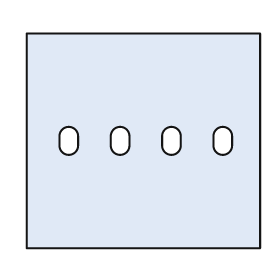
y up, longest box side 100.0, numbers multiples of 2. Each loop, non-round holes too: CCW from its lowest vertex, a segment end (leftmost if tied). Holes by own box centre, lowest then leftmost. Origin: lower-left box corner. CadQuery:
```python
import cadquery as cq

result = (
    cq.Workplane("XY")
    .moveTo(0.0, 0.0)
    .lineTo(100.0, 0.0)
    .lineTo(100.0, 92.0)
    .lineTo(0.0, 92.0)
    .close()
    .moveTo(14.0, 44.0)
    .threePointArc((18.0, 40.0), (22.0, 44.0))
    .lineTo(22.0, 48.0)
    .threePointArc((18.0, 52.0), (14.0, 48.0))
    .close()
    .moveTo(36.0, 44.0)
    .threePointArc((40.0, 40.0), (44.0, 44.0))
    .lineTo(44.0, 48.0)
    .threePointArc((40.0, 52.0), (36.0, 48.0))
    .close()
    .moveTo(58.0, 44.0)
    .threePointArc((62.0, 40.0), (66.0, 44.0))
    .lineTo(66.0, 48.0)
    .threePointArc((62.0, 52.0), (58.0, 48.0))
    .close()
    .moveTo(80.0, 44.0)
    .threePointArc((84.0, 40.0), (88.0, 44.0))
    .lineTo(88.0, 48.0)
    .threePointArc((84.0, 52.0), (80.0, 48.0))
    .close()
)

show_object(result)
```